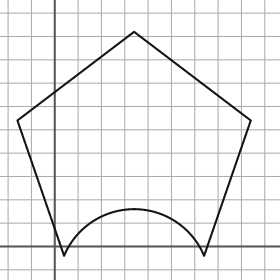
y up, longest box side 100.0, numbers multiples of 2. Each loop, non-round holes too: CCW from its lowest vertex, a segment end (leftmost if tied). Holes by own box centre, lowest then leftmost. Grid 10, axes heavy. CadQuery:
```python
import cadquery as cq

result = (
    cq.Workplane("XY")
    .moveTo(4.0, -4.0)
    .threePointArc((34.0, 16.0), (64.0, -4.0))
    .lineTo(84.0, 54.0)
    .lineTo(34.0, 92.0)
    .lineTo(-16.0, 54.0)
    .close()
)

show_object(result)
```